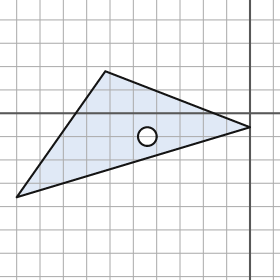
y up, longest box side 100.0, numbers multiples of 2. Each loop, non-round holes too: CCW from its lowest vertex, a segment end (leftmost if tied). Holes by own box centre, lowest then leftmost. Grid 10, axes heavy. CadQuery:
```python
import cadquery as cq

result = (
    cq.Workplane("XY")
    .moveTo(-100.0, -36.0)
    .lineTo(0.0, -6.0)
    .lineTo(-62.0, 18.0)
    .close()
    .moveTo(-44.0, -10.0)
    .circle(4.0)
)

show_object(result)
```